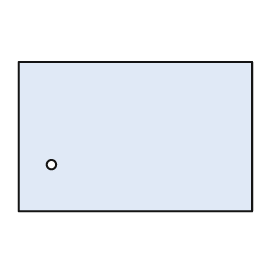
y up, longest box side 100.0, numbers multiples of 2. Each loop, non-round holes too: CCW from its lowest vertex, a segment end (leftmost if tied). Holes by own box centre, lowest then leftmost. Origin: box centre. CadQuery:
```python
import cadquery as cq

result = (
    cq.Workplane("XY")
    .moveTo(-50.0, -32.0)
    .lineTo(50.0, -32.0)
    .lineTo(50.0, 32.0)
    .lineTo(-50.0, 32.0)
    .close()
    .moveTo(-36.0, -12.0)
    .circle(2.0)
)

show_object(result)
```